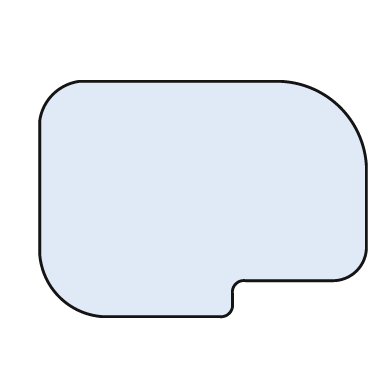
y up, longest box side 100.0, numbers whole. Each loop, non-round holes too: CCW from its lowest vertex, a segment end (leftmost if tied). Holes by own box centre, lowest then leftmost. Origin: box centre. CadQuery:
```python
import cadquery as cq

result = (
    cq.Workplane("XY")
    .moveTo(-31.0, -36.0)
    .lineTo(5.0, -36.0)
    .threePointArc((8.0, -35.0), (9.0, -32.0))
    .lineTo(9.0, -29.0)
    .threePointArc((10.0, -26.0), (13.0, -25.0))
    .lineTo(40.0, -25.0)
    .threePointArc((47.0, -22.0), (50.0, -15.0))
    .lineTo(50.0, 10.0)
    .threePointArc((42.0, 28.0), (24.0, 36.0))
    .lineTo(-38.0, 36.0)
    .threePointArc((-46.0, 32.0), (-50.0, 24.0))
    .lineTo(-50.0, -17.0)
    .threePointArc((-44.0, -30.0), (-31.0, -36.0))
    .close()
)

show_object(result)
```